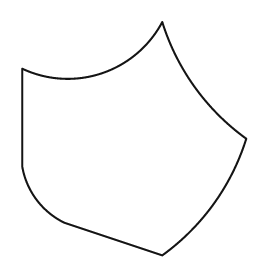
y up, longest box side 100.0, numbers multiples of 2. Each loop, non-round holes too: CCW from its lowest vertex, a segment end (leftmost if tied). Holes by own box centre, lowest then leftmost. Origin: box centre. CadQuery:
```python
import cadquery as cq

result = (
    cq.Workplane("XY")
    .moveTo(12.0, -50.0)
    .threePointArc((34.0, -28.0), (48.0, 0.0))
    .threePointArc((26.0, 22.0), (12.0, 50.0))
    .threePointArc((-14.0, 28.0), (-48.0, 30.0))
    .lineTo(-48.0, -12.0)
    .threePointArc((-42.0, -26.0), (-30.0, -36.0))
    .close()
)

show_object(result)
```